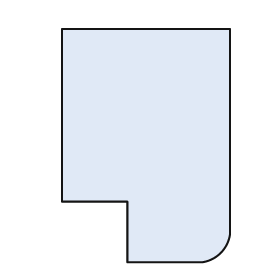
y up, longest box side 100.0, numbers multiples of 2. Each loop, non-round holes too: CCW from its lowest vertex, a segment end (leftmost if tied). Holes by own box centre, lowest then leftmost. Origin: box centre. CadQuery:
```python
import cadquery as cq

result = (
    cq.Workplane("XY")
    .moveTo(-8.0, -50.0)
    .lineTo(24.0, -50.0)
    .threePointArc((32.0, -46.0), (36.0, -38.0))
    .lineTo(36.0, 50.0)
    .lineTo(-36.0, 50.0)
    .lineTo(-36.0, -24.0)
    .lineTo(-8.0, -24.0)
    .close()
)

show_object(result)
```